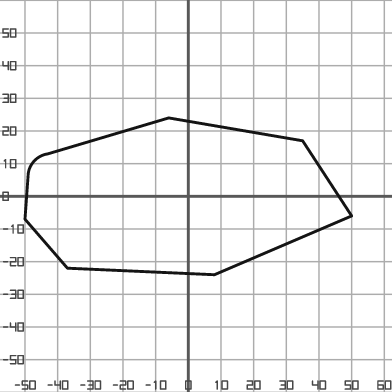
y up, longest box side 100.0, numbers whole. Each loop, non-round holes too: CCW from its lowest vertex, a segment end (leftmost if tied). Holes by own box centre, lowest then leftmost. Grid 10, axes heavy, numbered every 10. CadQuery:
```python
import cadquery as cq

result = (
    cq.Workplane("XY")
    .moveTo(8.0, -24.0)
    .lineTo(50.0, -6.0)
    .lineTo(35.0, 17.0)
    .lineTo(-6.0, 24.0)
    .lineTo(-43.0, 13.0)
    .threePointArc((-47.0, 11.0), (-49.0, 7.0))
    .lineTo(-50.0, -7.0)
    .lineTo(-37.0, -22.0)
    .close()
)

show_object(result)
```